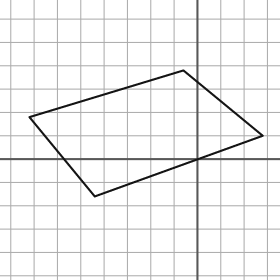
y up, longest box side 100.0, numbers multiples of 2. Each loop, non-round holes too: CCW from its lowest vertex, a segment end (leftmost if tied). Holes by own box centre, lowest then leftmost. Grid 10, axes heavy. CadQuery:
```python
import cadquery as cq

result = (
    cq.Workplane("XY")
    .moveTo(-44.0, -16.0)
    .lineTo(28.0, 10.0)
    .lineTo(-6.0, 38.0)
    .lineTo(-72.0, 18.0)
    .close()
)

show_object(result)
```